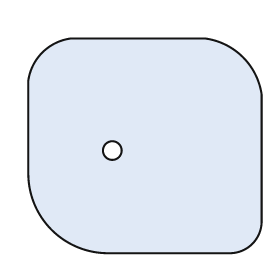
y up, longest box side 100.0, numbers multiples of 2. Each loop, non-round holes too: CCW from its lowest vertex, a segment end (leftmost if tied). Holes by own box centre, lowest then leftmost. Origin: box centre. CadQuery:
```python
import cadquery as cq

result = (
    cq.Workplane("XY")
    .moveTo(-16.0, -46.0)
    .lineTo(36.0, -46.0)
    .threePointArc((46.0, -42.0), (50.0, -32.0))
    .lineTo(50.0, 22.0)
    .threePointArc((42.0, 38.0), (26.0, 46.0))
    .lineTo(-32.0, 46.0)
    .threePointArc((-44.0, 40.0), (-50.0, 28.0))
    .lineTo(-50.0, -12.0)
    .threePointArc((-40.0, -36.0), (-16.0, -46.0))
    .close()
    .moveTo(-14.0, -2.0)
    .circle(4.0)
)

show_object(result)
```